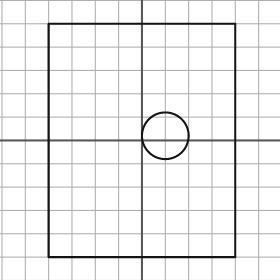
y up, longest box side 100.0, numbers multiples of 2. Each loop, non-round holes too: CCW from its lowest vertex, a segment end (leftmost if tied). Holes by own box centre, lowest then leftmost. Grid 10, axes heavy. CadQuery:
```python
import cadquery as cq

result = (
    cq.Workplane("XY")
    .moveTo(-40.0, -50.0)
    .lineTo(40.0, -50.0)
    .lineTo(40.0, 50.0)
    .lineTo(-40.0, 50.0)
    .close()
    .moveTo(10.0, 2.0)
    .circle(10.0)
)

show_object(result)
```